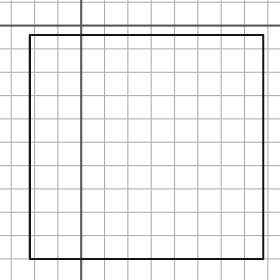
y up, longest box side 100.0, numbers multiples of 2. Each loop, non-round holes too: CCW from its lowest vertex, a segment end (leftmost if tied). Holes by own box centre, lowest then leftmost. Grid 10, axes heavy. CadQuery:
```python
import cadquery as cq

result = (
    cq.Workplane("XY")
    .moveTo(-22.0, -100.0)
    .lineTo(78.0, -100.0)
    .lineTo(78.0, -4.0)
    .lineTo(-22.0, -4.0)
    .close()
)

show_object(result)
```